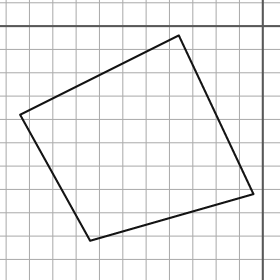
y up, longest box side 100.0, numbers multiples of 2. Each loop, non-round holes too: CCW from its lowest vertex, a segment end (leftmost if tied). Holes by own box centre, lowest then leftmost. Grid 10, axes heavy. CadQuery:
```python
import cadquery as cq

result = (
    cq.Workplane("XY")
    .moveTo(-74.0, -92.0)
    .lineTo(-4.0, -72.0)
    .lineTo(-36.0, -4.0)
    .lineTo(-104.0, -38.0)
    .close()
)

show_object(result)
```